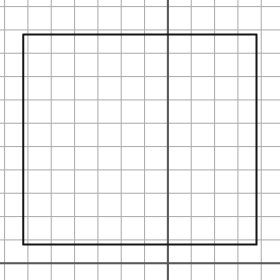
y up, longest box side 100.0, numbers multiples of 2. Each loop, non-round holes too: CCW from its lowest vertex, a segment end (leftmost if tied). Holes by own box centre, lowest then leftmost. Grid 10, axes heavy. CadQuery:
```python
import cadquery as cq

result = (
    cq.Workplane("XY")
    .moveTo(-62.0, 8.0)
    .lineTo(38.0, 8.0)
    .lineTo(38.0, 98.0)
    .lineTo(-62.0, 98.0)
    .close()
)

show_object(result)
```